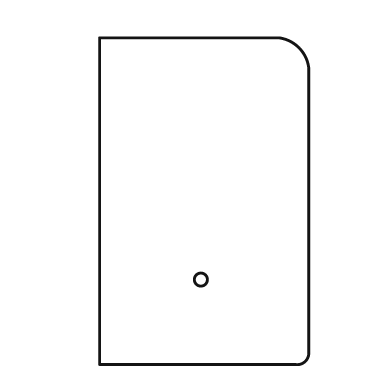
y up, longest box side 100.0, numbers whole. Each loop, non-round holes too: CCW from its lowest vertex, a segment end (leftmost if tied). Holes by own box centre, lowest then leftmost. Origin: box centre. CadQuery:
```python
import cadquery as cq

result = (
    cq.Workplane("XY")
    .moveTo(-32.0, -50.0)
    .lineTo(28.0, -50.0)
    .threePointArc((31.0, -49.0), (32.0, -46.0))
    .lineTo(32.0, 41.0)
    .threePointArc((29.0, 47.0), (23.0, 50.0))
    .lineTo(-32.0, 50.0)
    .close()
    .moveTo(-1.0, -24.0)
    .circle(2.0)
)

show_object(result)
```